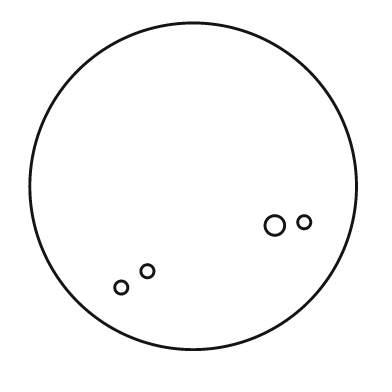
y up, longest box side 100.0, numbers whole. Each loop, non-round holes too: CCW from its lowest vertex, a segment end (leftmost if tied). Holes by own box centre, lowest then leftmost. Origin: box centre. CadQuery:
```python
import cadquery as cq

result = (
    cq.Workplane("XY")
    .moveTo(0.0, 0.0)
    .circle(50.0)
    .moveTo(-22.0, -31.0)
    .circle(2.0)
    .moveTo(-14.0, -26.0)
    .circle(2.0)
    .moveTo(25.0, -12.0)
    .circle(3.0)
    .moveTo(34.0, -11.0)
    .circle(2.0)
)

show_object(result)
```